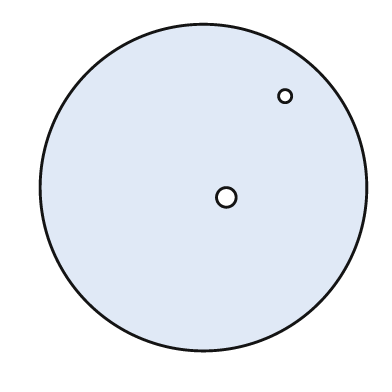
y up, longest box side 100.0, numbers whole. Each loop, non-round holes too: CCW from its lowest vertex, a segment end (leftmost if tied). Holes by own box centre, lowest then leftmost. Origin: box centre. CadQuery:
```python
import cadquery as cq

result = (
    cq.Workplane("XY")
    .moveTo(0.0, 0.0)
    .circle(50.0)
    .moveTo(7.0, -3.0)
    .circle(3.0)
    .moveTo(25.0, 28.0)
    .circle(2.0)
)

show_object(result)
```